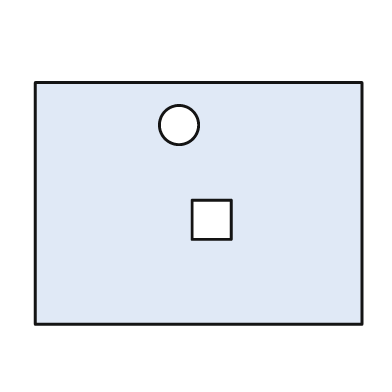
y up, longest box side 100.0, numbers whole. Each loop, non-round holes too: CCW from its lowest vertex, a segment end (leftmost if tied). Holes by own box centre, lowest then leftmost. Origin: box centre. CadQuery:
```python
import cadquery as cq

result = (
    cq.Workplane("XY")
    .moveTo(-50.0, -37.0)
    .lineTo(50.0, -37.0)
    .lineTo(50.0, 37.0)
    .lineTo(-50.0, 37.0)
    .close()
    .moveTo(-2.0, -11.0)
    .lineTo(10.0, -11.0)
    .lineTo(10.0, 1.0)
    .lineTo(-2.0, 1.0)
    .close()
    .moveTo(-6.0, 24.0)
    .circle(6.0)
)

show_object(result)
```